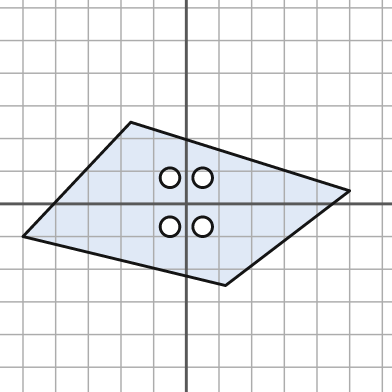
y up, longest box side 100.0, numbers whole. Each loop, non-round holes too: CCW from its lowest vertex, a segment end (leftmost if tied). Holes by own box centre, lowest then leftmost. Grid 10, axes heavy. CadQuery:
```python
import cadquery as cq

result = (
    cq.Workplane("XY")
    .moveTo(12.0, -25.0)
    .lineTo(50.0, 4.0)
    .lineTo(-17.0, 25.0)
    .lineTo(-50.0, -10.0)
    .close()
    .moveTo(-5.0, -7.0)
    .circle(3.0)
    .moveTo(5.0, -7.0)
    .circle(3.0)
    .moveTo(-5.0, 8.0)
    .circle(3.0)
    .moveTo(5.0, 8.0)
    .circle(3.0)
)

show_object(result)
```